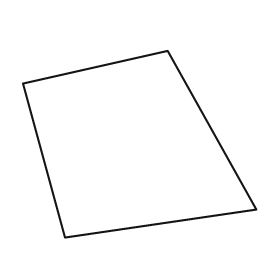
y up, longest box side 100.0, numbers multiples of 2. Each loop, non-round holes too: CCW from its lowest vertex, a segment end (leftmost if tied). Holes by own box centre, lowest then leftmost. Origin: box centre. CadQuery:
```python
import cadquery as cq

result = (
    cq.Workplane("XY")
    .moveTo(-32.0, -40.0)
    .lineTo(50.0, -28.0)
    .lineTo(12.0, 40.0)
    .lineTo(-50.0, 26.0)
    .close()
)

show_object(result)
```